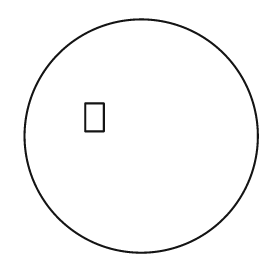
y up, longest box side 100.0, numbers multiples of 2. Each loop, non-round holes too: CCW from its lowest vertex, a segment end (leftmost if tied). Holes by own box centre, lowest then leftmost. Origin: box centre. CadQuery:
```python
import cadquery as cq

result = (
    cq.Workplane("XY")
    .moveTo(0.0, 0.0)
    .circle(50.0)
    .moveTo(-24.0, 2.0)
    .lineTo(-16.0, 2.0)
    .lineTo(-16.0, 14.0)
    .lineTo(-24.0, 14.0)
    .close()
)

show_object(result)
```